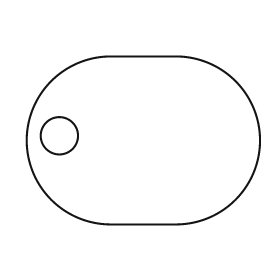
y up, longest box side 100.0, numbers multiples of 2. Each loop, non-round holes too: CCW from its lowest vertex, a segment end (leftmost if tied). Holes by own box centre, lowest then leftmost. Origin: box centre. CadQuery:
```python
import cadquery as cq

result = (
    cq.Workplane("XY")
    .moveTo(-14.0, -36.0)
    .lineTo(14.0, -36.0)
    .threePointArc((50.0, 0.0), (14.0, 36.0))
    .lineTo(-14.0, 36.0)
    .threePointArc((-50.0, 0.0), (-14.0, -36.0))
    .close()
    .moveTo(-36.0, 2.0)
    .circle(8.0)
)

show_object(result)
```